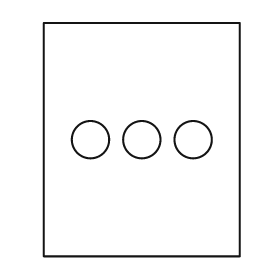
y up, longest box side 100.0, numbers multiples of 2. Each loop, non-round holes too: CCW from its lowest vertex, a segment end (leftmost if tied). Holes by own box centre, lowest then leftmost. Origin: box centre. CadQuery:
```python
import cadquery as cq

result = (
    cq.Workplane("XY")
    .moveTo(-42.0, -50.0)
    .lineTo(42.0, -50.0)
    .lineTo(42.0, 50.0)
    .lineTo(-42.0, 50.0)
    .close()
    .moveTo(-22.0, 0.0)
    .circle(8.0)
    .moveTo(0.0, 0.0)
    .circle(8.0)
    .moveTo(22.0, 0.0)
    .circle(8.0)
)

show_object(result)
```